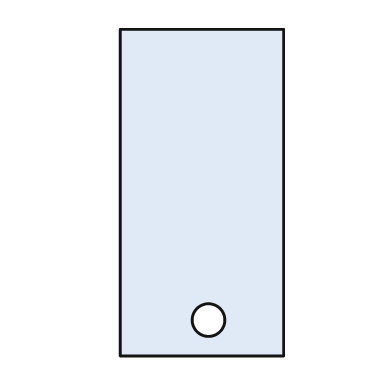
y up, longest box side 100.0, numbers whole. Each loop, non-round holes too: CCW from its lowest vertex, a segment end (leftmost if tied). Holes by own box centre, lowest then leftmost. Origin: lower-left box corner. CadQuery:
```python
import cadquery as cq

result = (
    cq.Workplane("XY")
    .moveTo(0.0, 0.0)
    .lineTo(50.0, 0.0)
    .lineTo(50.0, 100.0)
    .lineTo(0.0, 100.0)
    .close()
    .moveTo(27.0, 11.0)
    .circle(5.0)
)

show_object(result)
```